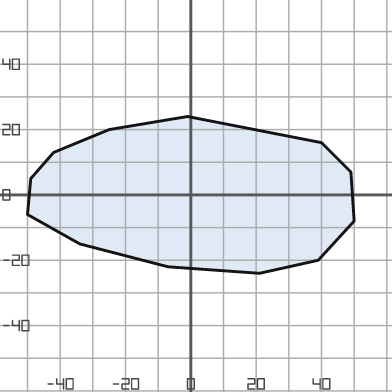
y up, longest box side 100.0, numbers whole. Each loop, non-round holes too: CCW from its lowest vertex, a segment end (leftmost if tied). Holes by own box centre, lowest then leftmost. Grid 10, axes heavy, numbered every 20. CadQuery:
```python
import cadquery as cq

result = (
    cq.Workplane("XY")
    .moveTo(21.0, -24.0)
    .lineTo(39.0, -20.0)
    .lineTo(50.0, -8.0)
    .lineTo(49.0, 7.0)
    .lineTo(40.0, 16.0)
    .lineTo(-1.0, 24.0)
    .lineTo(-25.0, 20.0)
    .lineTo(-42.0, 13.0)
    .lineTo(-49.0, 5.0)
    .lineTo(-50.0, -6.0)
    .lineTo(-34.0, -15.0)
    .lineTo(-7.0, -22.0)
    .close()
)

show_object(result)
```